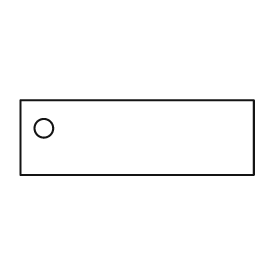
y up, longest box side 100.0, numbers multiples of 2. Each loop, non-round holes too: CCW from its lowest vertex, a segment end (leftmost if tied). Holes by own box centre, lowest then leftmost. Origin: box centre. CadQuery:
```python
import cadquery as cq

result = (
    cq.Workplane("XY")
    .moveTo(-50.0, -16.0)
    .lineTo(50.0, -16.0)
    .lineTo(50.0, 16.0)
    .lineTo(-50.0, 16.0)
    .close()
    .moveTo(-40.0, 4.0)
    .circle(4.0)
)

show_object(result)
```